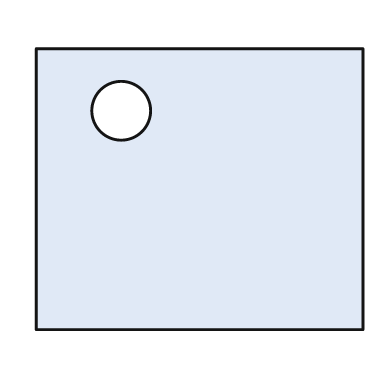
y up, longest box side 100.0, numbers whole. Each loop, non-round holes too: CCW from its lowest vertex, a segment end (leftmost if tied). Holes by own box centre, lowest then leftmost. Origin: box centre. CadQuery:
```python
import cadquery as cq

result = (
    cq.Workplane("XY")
    .moveTo(-50.0, -43.0)
    .lineTo(50.0, -43.0)
    .lineTo(50.0, 43.0)
    .lineTo(-50.0, 43.0)
    .close()
    .moveTo(-24.0, 24.0)
    .circle(9.0)
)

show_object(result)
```